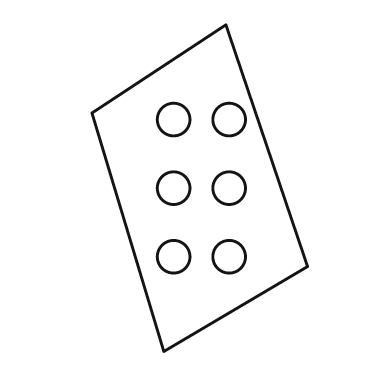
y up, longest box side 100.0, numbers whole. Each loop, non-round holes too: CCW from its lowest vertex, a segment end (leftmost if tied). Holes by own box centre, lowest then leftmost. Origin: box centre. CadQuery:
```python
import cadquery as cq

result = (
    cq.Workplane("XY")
    .moveTo(-11.0, -50.0)
    .lineTo(33.0, -24.0)
    .lineTo(8.0, 50.0)
    .lineTo(-33.0, 23.0)
    .close()
    .moveTo(-8.0, -21.0)
    .circle(5.0)
    .moveTo(9.0, -21.0)
    .circle(5.0)
    .moveTo(-8.0, 0.0)
    .circle(5.0)
    .moveTo(9.0, 0.0)
    .circle(5.0)
    .moveTo(-8.0, 21.0)
    .circle(5.0)
    .moveTo(9.0, 21.0)
    .circle(5.0)
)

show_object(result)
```